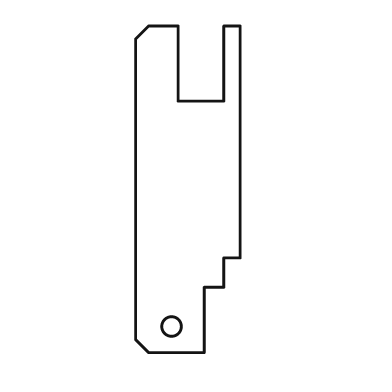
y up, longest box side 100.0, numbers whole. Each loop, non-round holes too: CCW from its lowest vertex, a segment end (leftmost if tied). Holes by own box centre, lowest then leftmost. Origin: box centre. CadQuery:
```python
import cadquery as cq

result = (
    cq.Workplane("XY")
    .moveTo(-12.0, -50.0)
    .lineTo(5.0, -50.0)
    .lineTo(5.0, -30.0)
    .lineTo(11.0, -30.0)
    .lineTo(11.0, -21.0)
    .lineTo(16.0, -21.0)
    .lineTo(16.0, 50.0)
    .lineTo(11.0, 50.0)
    .lineTo(11.0, 27.0)
    .lineTo(-3.0, 27.0)
    .lineTo(-3.0, 50.0)
    .lineTo(-12.0, 50.0)
    .lineTo(-16.0, 46.0)
    .lineTo(-16.0, -46.0)
    .close()
    .moveTo(-5.0, -42.0)
    .circle(3.0)
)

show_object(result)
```